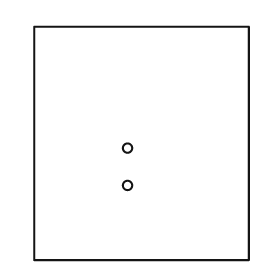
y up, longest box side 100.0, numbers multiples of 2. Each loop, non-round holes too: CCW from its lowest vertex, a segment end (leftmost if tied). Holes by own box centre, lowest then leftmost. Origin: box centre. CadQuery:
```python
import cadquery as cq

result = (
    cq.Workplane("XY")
    .moveTo(-46.0, -50.0)
    .lineTo(46.0, -50.0)
    .lineTo(46.0, 50.0)
    .lineTo(-46.0, 50.0)
    .close()
    .moveTo(-6.0, -18.0)
    .circle(2.0)
    .moveTo(-6.0, -2.0)
    .circle(2.0)
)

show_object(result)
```